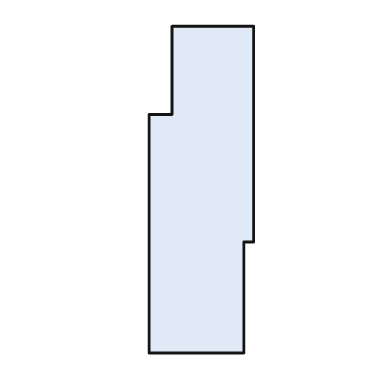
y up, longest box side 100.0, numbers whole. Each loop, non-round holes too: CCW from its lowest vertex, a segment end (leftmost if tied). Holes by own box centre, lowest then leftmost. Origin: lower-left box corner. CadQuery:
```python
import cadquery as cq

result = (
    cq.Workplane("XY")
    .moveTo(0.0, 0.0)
    .lineTo(29.0, 0.0)
    .lineTo(29.0, 34.0)
    .lineTo(32.0, 34.0)
    .lineTo(32.0, 100.0)
    .lineTo(7.0, 100.0)
    .lineTo(7.0, 73.0)
    .lineTo(0.0, 73.0)
    .close()
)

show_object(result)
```